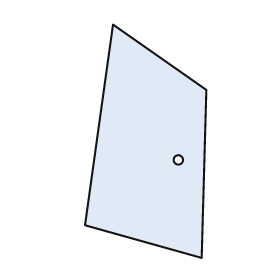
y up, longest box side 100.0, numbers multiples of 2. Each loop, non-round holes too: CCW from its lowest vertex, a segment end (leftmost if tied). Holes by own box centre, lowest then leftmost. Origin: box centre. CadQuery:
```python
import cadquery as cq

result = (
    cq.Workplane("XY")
    .moveTo(24.0, -50.0)
    .lineTo(26.0, 22.0)
    .lineTo(-14.0, 50.0)
    .lineTo(-26.0, -36.0)
    .close()
    .moveTo(14.0, -8.0)
    .circle(2.0)
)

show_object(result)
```